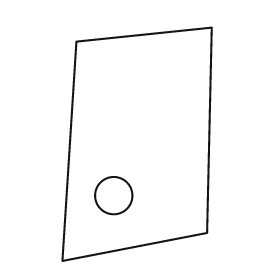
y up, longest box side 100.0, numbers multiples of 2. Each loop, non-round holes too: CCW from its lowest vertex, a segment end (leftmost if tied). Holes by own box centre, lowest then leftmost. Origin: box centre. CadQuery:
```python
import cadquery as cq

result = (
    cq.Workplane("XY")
    .moveTo(-32.0, -50.0)
    .lineTo(30.0, -38.0)
    .lineTo(32.0, 50.0)
    .lineTo(-26.0, 44.0)
    .close()
    .moveTo(-10.0, -22.0)
    .circle(8.0)
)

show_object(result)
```